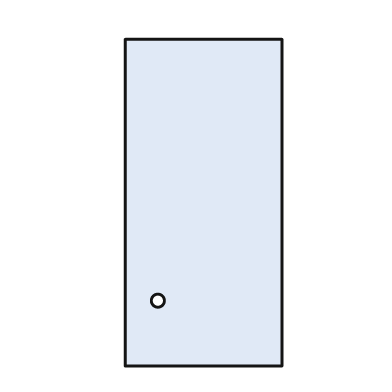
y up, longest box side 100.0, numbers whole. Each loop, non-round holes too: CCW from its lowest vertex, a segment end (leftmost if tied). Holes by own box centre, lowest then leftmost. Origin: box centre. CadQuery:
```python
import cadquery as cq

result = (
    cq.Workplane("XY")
    .moveTo(-24.0, -50.0)
    .lineTo(24.0, -50.0)
    .lineTo(24.0, 50.0)
    .lineTo(-24.0, 50.0)
    .close()
    .moveTo(-14.0, -30.0)
    .circle(2.0)
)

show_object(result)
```